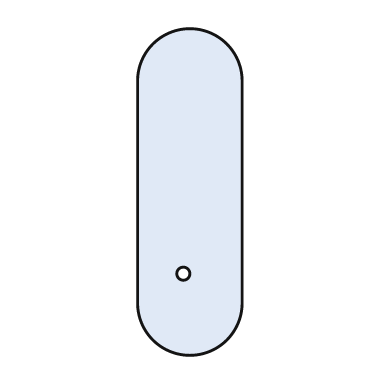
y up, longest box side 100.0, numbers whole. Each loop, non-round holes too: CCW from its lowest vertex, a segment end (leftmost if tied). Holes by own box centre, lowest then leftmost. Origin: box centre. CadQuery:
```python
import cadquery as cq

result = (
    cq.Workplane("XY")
    .moveTo(-16.0, -34.0)
    .threePointArc((0.0, -50.0), (16.0, -34.0))
    .lineTo(16.0, 34.0)
    .threePointArc((0.0, 50.0), (-16.0, 34.0))
    .close()
    .moveTo(-2.0, -25.0)
    .circle(2.0)
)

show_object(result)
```